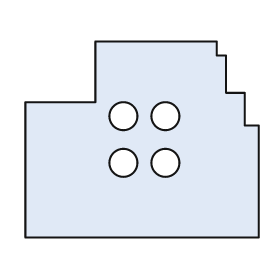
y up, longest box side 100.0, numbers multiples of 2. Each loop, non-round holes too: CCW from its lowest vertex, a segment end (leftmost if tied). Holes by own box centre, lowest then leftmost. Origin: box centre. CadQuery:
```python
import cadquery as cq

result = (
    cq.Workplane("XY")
    .moveTo(-50.0, -42.0)
    .lineTo(50.0, -42.0)
    .lineTo(50.0, 6.0)
    .lineTo(44.0, 6.0)
    .lineTo(44.0, 20.0)
    .lineTo(36.0, 20.0)
    .lineTo(36.0, 36.0)
    .lineTo(32.0, 36.0)
    .lineTo(32.0, 42.0)
    .lineTo(-20.0, 42.0)
    .lineTo(-20.0, 16.0)
    .lineTo(-50.0, 16.0)
    .close()
    .moveTo(-8.0, -10.0)
    .circle(6.0)
    .moveTo(10.0, -10.0)
    .circle(6.0)
    .moveTo(-8.0, 10.0)
    .circle(6.0)
    .moveTo(10.0, 10.0)
    .circle(6.0)
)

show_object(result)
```